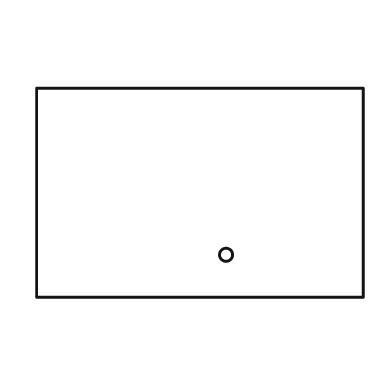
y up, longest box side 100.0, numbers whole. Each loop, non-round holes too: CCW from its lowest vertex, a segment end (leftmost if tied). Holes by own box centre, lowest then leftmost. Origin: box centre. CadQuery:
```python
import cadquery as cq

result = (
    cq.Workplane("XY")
    .moveTo(-50.0, -32.0)
    .lineTo(50.0, -32.0)
    .lineTo(50.0, 32.0)
    .lineTo(-50.0, 32.0)
    .close()
    .moveTo(8.0, -19.0)
    .circle(2.0)
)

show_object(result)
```